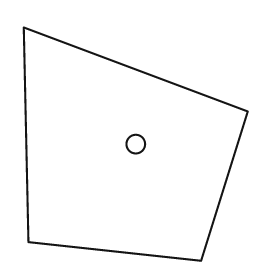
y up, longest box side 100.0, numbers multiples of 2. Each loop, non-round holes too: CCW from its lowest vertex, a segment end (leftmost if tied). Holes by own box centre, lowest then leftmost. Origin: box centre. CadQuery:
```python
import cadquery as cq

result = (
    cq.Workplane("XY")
    .moveTo(28.0, -50.0)
    .lineTo(48.0, 14.0)
    .lineTo(-48.0, 50.0)
    .lineTo(-46.0, -42.0)
    .close()
    .moveTo(0.0, 0.0)
    .circle(4.0)
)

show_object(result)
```